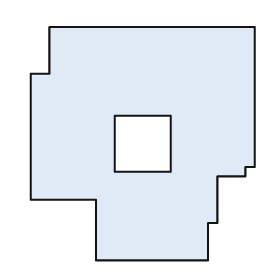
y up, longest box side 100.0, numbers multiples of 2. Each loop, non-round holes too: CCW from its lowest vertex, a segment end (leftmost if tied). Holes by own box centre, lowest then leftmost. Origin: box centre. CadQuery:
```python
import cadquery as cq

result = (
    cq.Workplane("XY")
    .moveTo(-20.0, -50.0)
    .lineTo(28.0, -50.0)
    .lineTo(28.0, -34.0)
    .lineTo(32.0, -34.0)
    .lineTo(32.0, -14.0)
    .lineTo(44.0, -14.0)
    .lineTo(44.0, -10.0)
    .lineTo(48.0, -10.0)
    .lineTo(48.0, 50.0)
    .lineTo(-40.0, 50.0)
    .lineTo(-40.0, 30.0)
    .lineTo(-48.0, 30.0)
    .lineTo(-48.0, -24.0)
    .lineTo(-20.0, -24.0)
    .close()
    .moveTo(-12.0, -12.0)
    .lineTo(12.0, -12.0)
    .lineTo(12.0, 12.0)
    .lineTo(-12.0, 12.0)
    .close()
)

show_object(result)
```